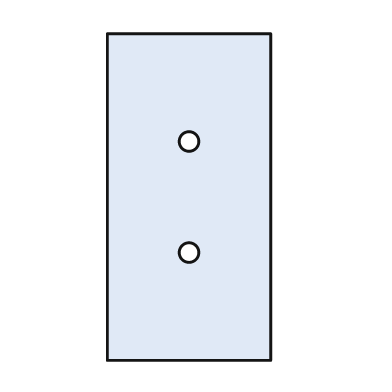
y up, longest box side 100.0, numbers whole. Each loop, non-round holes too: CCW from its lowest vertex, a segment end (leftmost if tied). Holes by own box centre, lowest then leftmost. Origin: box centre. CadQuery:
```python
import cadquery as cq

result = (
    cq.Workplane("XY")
    .moveTo(-25.0, -50.0)
    .lineTo(25.0, -50.0)
    .lineTo(25.0, 50.0)
    .lineTo(-25.0, 50.0)
    .close()
    .moveTo(0.0, -17.0)
    .circle(3.0)
    .moveTo(0.0, 17.0)
    .circle(3.0)
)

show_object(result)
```